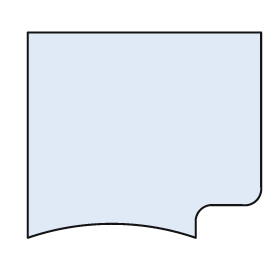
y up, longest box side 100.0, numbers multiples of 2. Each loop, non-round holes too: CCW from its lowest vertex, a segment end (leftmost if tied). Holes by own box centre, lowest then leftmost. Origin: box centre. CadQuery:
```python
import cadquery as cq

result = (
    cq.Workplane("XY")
    .moveTo(-50.0, -44.0)
    .threePointArc((-14.0, -38.0), (22.0, -44.0))
    .lineTo(22.0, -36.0)
    .threePointArc((24.0, -32.0), (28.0, -30.0))
    .lineTo(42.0, -30.0)
    .threePointArc((48.0, -28.0), (50.0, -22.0))
    .lineTo(50.0, 44.0)
    .lineTo(-50.0, 44.0)
    .close()
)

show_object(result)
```